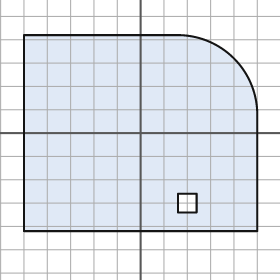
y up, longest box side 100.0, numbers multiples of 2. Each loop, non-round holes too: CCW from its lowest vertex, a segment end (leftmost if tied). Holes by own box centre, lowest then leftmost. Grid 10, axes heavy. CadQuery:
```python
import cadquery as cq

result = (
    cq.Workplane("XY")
    .moveTo(-50.0, -42.0)
    .lineTo(50.0, -42.0)
    .lineTo(50.0, 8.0)
    .threePointArc((40.0, 32.0), (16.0, 42.0))
    .lineTo(-50.0, 42.0)
    .close()
    .moveTo(16.0, -34.0)
    .lineTo(24.0, -34.0)
    .lineTo(24.0, -26.0)
    .lineTo(16.0, -26.0)
    .close()
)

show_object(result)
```